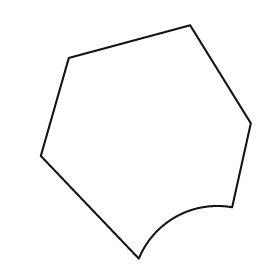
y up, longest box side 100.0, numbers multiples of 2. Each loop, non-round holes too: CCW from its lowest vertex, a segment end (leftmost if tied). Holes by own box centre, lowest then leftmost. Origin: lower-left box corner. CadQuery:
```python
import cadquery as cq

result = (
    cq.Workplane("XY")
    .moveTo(42.0, 0.0)
    .threePointArc((58.0, 18.0), (82.0, 22.0))
    .lineTo(90.0, 58.0)
    .lineTo(64.0, 100.0)
    .lineTo(12.0, 86.0)
    .lineTo(0.0, 44.0)
    .close()
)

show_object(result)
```